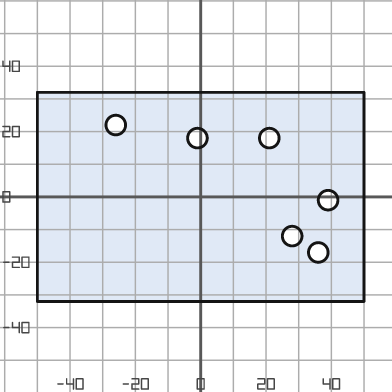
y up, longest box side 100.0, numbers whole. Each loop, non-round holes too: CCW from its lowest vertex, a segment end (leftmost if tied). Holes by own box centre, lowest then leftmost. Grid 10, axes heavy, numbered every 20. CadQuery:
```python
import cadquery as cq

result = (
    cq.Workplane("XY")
    .moveTo(-50.0, -32.0)
    .lineTo(50.0, -32.0)
    .lineTo(50.0, 32.0)
    .lineTo(-50.0, 32.0)
    .close()
    .moveTo(36.0, -17.0)
    .circle(3.0)
    .moveTo(28.0, -12.0)
    .circle(3.0)
    .moveTo(39.0, -1.0)
    .circle(3.0)
    .moveTo(-1.0, 18.0)
    .circle(3.0)
    .moveTo(21.0, 18.0)
    .circle(3.0)
    .moveTo(-26.0, 22.0)
    .circle(3.0)
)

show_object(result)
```